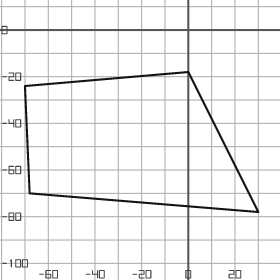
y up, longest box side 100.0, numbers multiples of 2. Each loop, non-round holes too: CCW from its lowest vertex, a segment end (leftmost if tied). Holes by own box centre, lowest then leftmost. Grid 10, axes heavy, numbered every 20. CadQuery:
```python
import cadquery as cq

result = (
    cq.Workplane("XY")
    .moveTo(30.0, -78.0)
    .lineTo(0.0, -18.0)
    .lineTo(-70.0, -24.0)
    .lineTo(-68.0, -70.0)
    .close()
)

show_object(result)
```